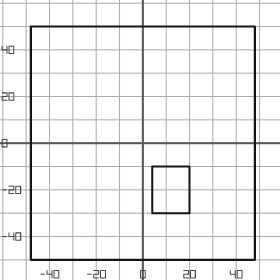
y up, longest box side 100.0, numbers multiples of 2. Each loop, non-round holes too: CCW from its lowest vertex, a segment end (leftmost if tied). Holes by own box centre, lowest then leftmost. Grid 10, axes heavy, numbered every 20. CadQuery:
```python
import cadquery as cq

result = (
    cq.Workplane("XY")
    .moveTo(-48.0, -50.0)
    .lineTo(48.0, -50.0)
    .lineTo(48.0, 50.0)
    .lineTo(-48.0, 50.0)
    .close()
    .moveTo(4.0, -30.0)
    .lineTo(20.0, -30.0)
    .lineTo(20.0, -10.0)
    .lineTo(4.0, -10.0)
    .close()
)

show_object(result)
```